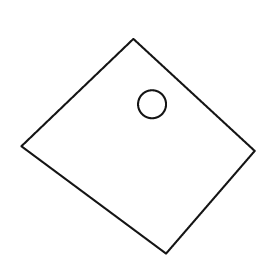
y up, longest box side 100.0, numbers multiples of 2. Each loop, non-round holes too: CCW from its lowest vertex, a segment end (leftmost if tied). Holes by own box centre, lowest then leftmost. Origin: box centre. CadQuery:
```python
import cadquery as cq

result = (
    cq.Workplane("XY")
    .moveTo(12.0, -46.0)
    .lineTo(50.0, -2.0)
    .lineTo(-2.0, 46.0)
    .lineTo(-50.0, 0.0)
    .close()
    .moveTo(6.0, 18.0)
    .circle(6.0)
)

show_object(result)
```